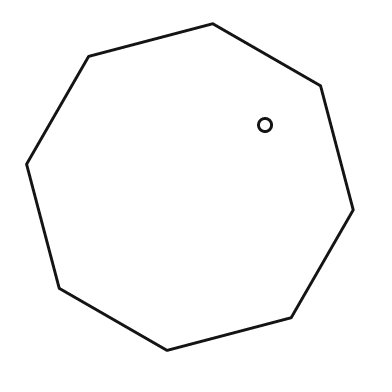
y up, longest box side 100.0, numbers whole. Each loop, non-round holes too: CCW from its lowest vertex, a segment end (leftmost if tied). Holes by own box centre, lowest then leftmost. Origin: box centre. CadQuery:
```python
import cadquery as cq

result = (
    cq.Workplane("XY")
    .moveTo(-7.0, -50.0)
    .lineTo(31.0, -40.0)
    .lineTo(50.0, -7.0)
    .lineTo(40.0, 31.0)
    .lineTo(7.0, 50.0)
    .lineTo(-31.0, 40.0)
    .lineTo(-50.0, 7.0)
    .lineTo(-40.0, -31.0)
    .close()
    .moveTo(23.0, 19.0)
    .circle(2.0)
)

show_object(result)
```